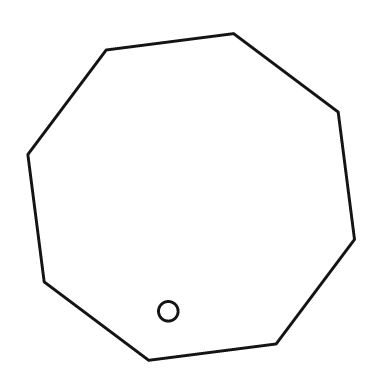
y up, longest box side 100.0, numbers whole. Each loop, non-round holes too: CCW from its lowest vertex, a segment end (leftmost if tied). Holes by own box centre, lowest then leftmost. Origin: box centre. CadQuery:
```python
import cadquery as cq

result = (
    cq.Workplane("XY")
    .moveTo(-13.0, -50.0)
    .lineTo(26.0, -45.0)
    .lineTo(50.0, -13.0)
    .lineTo(45.0, 26.0)
    .lineTo(13.0, 50.0)
    .lineTo(-26.0, 45.0)
    .lineTo(-50.0, 13.0)
    .lineTo(-45.0, -26.0)
    .close()
    .moveTo(-7.0, -35.0)
    .circle(3.0)
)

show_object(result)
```